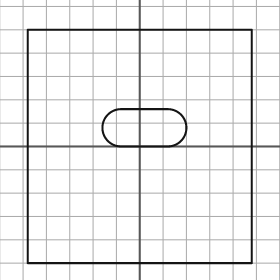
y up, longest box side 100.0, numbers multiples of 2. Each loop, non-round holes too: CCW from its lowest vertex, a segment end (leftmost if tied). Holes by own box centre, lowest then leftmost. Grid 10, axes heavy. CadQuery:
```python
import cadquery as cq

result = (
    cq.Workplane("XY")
    .moveTo(-48.0, -50.0)
    .lineTo(48.0, -50.0)
    .lineTo(48.0, 50.0)
    .lineTo(-48.0, 50.0)
    .close()
    .moveTo(-8.0, 0.0)
    .lineTo(12.0, 0.0)
    .threePointArc((20.0, 8.0), (12.0, 16.0))
    .lineTo(-8.0, 16.0)
    .threePointArc((-16.0, 8.0), (-8.0, 0.0))
    .close()
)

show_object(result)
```